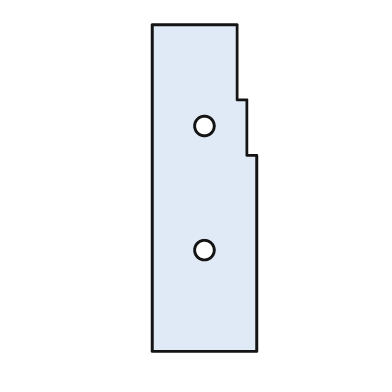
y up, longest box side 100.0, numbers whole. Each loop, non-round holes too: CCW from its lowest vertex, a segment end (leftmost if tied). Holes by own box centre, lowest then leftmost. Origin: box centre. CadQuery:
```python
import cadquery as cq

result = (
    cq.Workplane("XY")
    .moveTo(-16.0, -50.0)
    .lineTo(16.0, -50.0)
    .lineTo(16.0, 10.0)
    .lineTo(13.0, 10.0)
    .lineTo(13.0, 27.0)
    .lineTo(10.0, 27.0)
    .lineTo(10.0, 50.0)
    .lineTo(-16.0, 50.0)
    .close()
    .moveTo(0.0, -19.0)
    .circle(3.0)
    .moveTo(0.0, 19.0)
    .circle(3.0)
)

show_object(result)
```